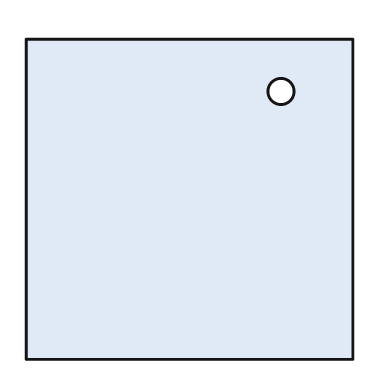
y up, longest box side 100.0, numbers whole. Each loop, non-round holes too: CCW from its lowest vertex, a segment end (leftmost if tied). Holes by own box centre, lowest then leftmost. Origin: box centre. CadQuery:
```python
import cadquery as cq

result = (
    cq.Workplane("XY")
    .moveTo(-50.0, -49.0)
    .lineTo(50.0, -49.0)
    .lineTo(50.0, 49.0)
    .lineTo(-50.0, 49.0)
    .close()
    .moveTo(28.0, 33.0)
    .circle(4.0)
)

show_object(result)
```